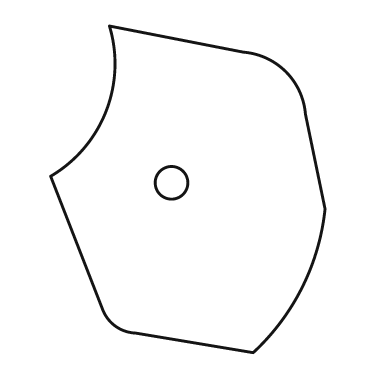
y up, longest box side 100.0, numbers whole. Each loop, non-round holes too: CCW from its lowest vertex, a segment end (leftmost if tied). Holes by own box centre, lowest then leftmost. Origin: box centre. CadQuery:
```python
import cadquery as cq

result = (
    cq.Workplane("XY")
    .moveTo(20.0, -50.0)
    .threePointArc((35.0, -30.0), (42.0, -6.0))
    .lineTo(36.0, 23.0)
    .threePointArc((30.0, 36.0), (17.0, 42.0))
    .lineTo(-24.0, 50.0)
    .threePointArc((-25.0, 24.0), (-42.0, 4.0))
    .lineTo(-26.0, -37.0)
    .threePointArc((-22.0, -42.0), (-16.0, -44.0))
    .close()
    .moveTo(-5.0, 2.0)
    .circle(5.0)
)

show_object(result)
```